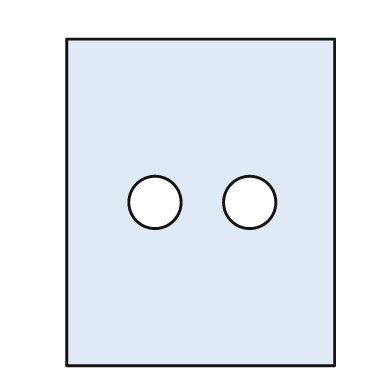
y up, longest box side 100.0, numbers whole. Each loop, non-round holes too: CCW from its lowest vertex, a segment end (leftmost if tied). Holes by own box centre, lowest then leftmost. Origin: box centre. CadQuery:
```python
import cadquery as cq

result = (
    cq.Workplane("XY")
    .moveTo(-41.0, -50.0)
    .lineTo(41.0, -50.0)
    .lineTo(41.0, 50.0)
    .lineTo(-41.0, 50.0)
    .close()
    .moveTo(-14.0, 0.0)
    .circle(8.0)
    .moveTo(15.0, 0.0)
    .circle(8.0)
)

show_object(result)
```